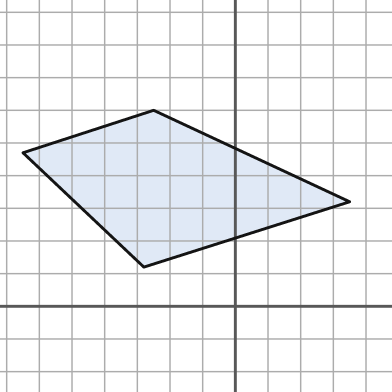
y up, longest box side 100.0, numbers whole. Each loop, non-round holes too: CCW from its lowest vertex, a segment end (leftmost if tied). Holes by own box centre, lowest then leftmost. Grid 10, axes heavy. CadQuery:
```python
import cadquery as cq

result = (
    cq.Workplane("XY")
    .moveTo(-28.0, 12.0)
    .lineTo(35.0, 32.0)
    .lineTo(-25.0, 60.0)
    .lineTo(-65.0, 47.0)
    .close()
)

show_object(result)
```